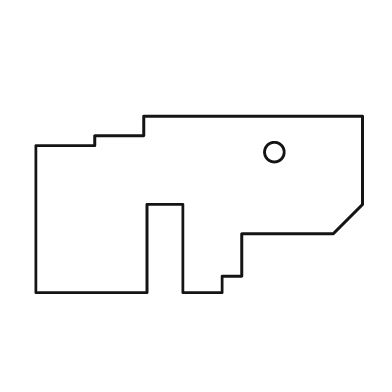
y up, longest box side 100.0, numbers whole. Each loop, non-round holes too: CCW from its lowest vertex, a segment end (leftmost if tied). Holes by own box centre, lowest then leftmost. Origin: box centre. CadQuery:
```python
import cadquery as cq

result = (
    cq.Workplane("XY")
    .moveTo(-50.0, -27.0)
    .lineTo(-16.0, -27.0)
    .lineTo(-16.0, 0.0)
    .lineTo(-5.0, 0.0)
    .lineTo(-5.0, -27.0)
    .lineTo(7.0, -27.0)
    .lineTo(7.0, -22.0)
    .lineTo(13.0, -22.0)
    .lineTo(13.0, -9.0)
    .lineTo(41.0, -9.0)
    .lineTo(50.0, 0.0)
    .lineTo(50.0, 27.0)
    .lineTo(-17.0, 27.0)
    .lineTo(-17.0, 21.0)
    .lineTo(-32.0, 21.0)
    .lineTo(-32.0, 18.0)
    .lineTo(-50.0, 18.0)
    .close()
    .moveTo(23.0, 16.0)
    .circle(3.0)
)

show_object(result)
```